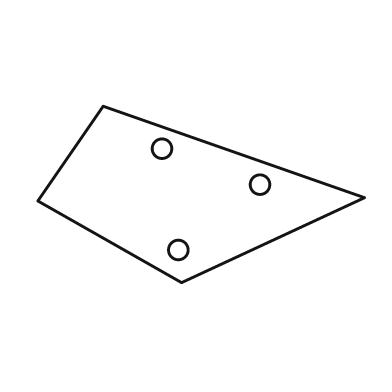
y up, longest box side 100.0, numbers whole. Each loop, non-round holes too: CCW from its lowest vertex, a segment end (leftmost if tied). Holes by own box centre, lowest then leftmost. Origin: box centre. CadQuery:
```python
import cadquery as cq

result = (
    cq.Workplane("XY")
    .moveTo(-6.0, -27.0)
    .lineTo(50.0, -1.0)
    .lineTo(-30.0, 27.0)
    .lineTo(-50.0, -2.0)
    .close()
    .moveTo(-7.0, -17.0)
    .circle(3.0)
    .moveTo(18.0, 3.0)
    .circle(3.0)
    .moveTo(-12.0, 14.0)
    .circle(3.0)
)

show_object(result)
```